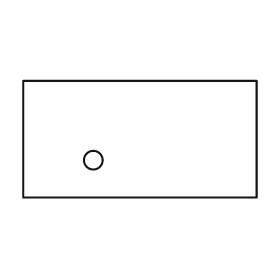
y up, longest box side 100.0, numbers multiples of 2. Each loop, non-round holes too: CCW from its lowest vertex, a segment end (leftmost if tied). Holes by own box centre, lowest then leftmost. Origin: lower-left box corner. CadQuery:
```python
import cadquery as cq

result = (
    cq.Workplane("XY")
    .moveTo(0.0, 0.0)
    .lineTo(100.0, 0.0)
    .lineTo(100.0, 50.0)
    .lineTo(0.0, 50.0)
    .close()
    .moveTo(30.0, 16.0)
    .circle(4.0)
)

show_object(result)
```